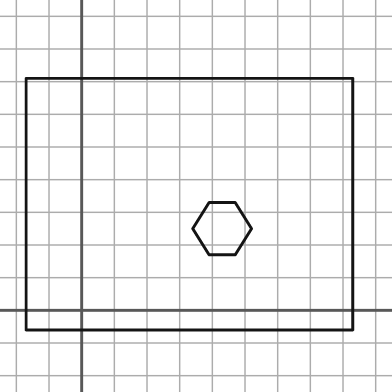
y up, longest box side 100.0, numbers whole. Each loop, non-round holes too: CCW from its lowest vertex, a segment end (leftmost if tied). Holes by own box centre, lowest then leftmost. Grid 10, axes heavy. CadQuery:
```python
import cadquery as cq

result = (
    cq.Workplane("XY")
    .moveTo(-17.0, -6.0)
    .lineTo(83.0, -6.0)
    .lineTo(83.0, 71.0)
    .lineTo(-17.0, 71.0)
    .close()
    .moveTo(39.0, 17.0)
    .lineTo(47.0, 17.0)
    .lineTo(52.0, 25.0)
    .lineTo(47.0, 33.0)
    .lineTo(39.0, 33.0)
    .lineTo(34.0, 25.0)
    .close()
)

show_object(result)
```